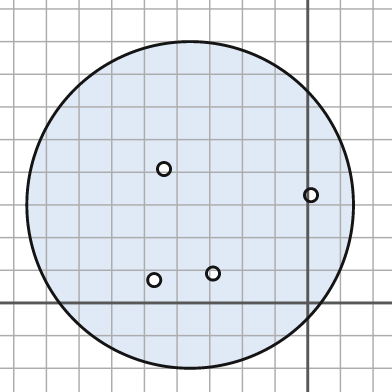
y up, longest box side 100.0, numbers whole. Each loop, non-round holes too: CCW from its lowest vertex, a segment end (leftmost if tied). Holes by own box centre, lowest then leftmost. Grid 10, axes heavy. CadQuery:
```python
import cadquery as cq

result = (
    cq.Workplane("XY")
    .moveTo(-36.0, 30.0)
    .circle(50.0)
    .moveTo(-47.0, 7.0)
    .circle(2.0)
    .moveTo(-29.0, 9.0)
    .circle(2.0)
    .moveTo(1.0, 33.0)
    .circle(2.0)
    .moveTo(-44.0, 41.0)
    .circle(2.0)
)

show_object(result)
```